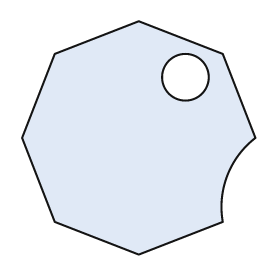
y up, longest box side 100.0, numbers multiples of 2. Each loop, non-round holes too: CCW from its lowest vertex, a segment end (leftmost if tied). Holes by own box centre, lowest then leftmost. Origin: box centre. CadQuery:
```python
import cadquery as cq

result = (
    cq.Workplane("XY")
    .moveTo(0.0, -50.0)
    .lineTo(36.0, -36.0)
    .threePointArc((38.0, -16.0), (50.0, 0.0))
    .lineTo(36.0, 36.0)
    .lineTo(0.0, 50.0)
    .lineTo(-36.0, 36.0)
    .lineTo(-50.0, 0.0)
    .lineTo(-36.0, -36.0)
    .close()
    .moveTo(20.0, 26.0)
    .circle(10.0)
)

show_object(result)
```